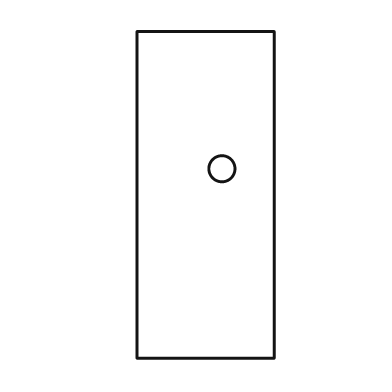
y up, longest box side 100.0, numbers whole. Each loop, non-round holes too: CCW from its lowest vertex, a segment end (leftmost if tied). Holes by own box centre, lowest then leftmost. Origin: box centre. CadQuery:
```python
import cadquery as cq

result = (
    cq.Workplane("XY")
    .moveTo(-21.0, -50.0)
    .lineTo(21.0, -50.0)
    .lineTo(21.0, 50.0)
    .lineTo(-21.0, 50.0)
    .close()
    .moveTo(5.0, 8.0)
    .circle(4.0)
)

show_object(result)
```